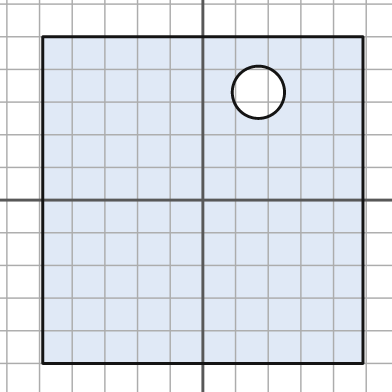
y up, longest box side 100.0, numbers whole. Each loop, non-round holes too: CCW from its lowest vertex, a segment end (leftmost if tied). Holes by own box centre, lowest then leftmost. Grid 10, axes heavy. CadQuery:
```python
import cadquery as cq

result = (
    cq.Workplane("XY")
    .moveTo(-49.0, -50.0)
    .lineTo(49.0, -50.0)
    .lineTo(49.0, 50.0)
    .lineTo(-49.0, 50.0)
    .close()
    .moveTo(17.0, 33.0)
    .circle(8.0)
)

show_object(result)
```